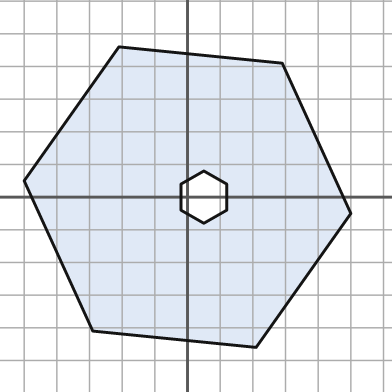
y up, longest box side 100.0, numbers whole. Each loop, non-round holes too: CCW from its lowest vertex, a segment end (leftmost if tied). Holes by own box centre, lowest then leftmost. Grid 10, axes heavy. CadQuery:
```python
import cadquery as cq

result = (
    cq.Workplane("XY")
    .moveTo(21.0, -46.0)
    .lineTo(50.0, -5.0)
    .lineTo(29.0, 41.0)
    .lineTo(-21.0, 46.0)
    .lineTo(-50.0, 5.0)
    .lineTo(-29.0, -41.0)
    .close()
    .moveTo(5.0, -8.0)
    .lineTo(12.0, -4.0)
    .lineTo(12.0, 4.0)
    .lineTo(5.0, 8.0)
    .lineTo(-2.0, 4.0)
    .lineTo(-2.0, -4.0)
    .close()
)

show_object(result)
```